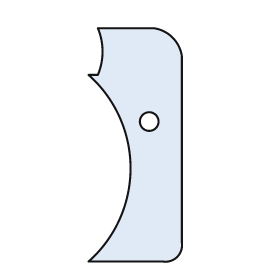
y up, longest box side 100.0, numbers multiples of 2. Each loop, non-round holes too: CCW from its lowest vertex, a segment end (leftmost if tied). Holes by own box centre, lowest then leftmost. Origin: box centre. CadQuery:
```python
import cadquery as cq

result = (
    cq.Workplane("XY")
    .moveTo(-20.0, -50.0)
    .lineTo(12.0, -50.0)
    .threePointArc((18.0, -48.0), (20.0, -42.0))
    .lineTo(20.0, 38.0)
    .threePointArc((16.0, 46.0), (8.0, 50.0))
    .lineTo(-16.0, 50.0)
    .threePointArc((-14.0, 40.0), (-16.0, 30.0))
    .lineTo(-20.0, 30.0)
    .threePointArc((-2.0, -10.0), (-20.0, -50.0))
    .close()
    .moveTo(6.0, 10.0)
    .circle(4.0)
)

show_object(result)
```